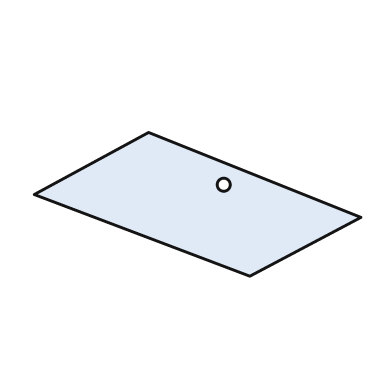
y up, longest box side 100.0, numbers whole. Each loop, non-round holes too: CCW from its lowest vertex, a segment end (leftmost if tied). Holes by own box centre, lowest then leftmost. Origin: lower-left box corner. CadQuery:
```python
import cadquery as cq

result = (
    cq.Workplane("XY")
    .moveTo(66.0, 0.0)
    .lineTo(100.0, 18.0)
    .lineTo(35.0, 44.0)
    .lineTo(0.0, 25.0)
    .close()
    .moveTo(58.0, 28.0)
    .circle(2.0)
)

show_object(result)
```